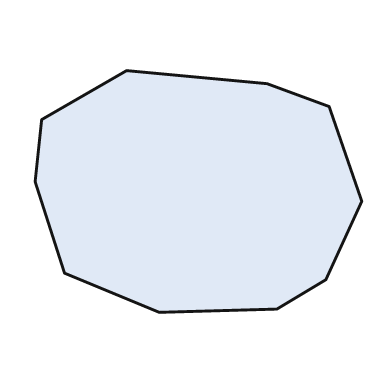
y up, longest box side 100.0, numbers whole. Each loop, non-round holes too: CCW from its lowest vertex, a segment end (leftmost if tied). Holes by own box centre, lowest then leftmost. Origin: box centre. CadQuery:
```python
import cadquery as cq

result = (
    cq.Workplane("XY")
    .moveTo(-12.0, -37.0)
    .lineTo(24.0, -36.0)
    .lineTo(39.0, -27.0)
    .lineTo(50.0, -3.0)
    .lineTo(40.0, 26.0)
    .lineTo(21.0, 33.0)
    .lineTo(-22.0, 37.0)
    .lineTo(-48.0, 22.0)
    .lineTo(-50.0, 3.0)
    .lineTo(-41.0, -25.0)
    .close()
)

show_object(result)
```